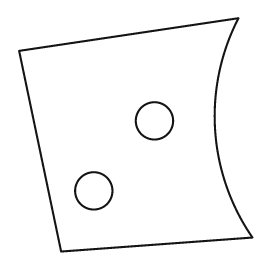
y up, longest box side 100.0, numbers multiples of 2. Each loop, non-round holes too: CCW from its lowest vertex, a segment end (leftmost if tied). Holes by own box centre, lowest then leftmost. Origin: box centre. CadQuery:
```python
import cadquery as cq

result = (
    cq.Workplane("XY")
    .moveTo(-32.0, -50.0)
    .lineTo(50.0, -44.0)
    .threePointArc((34.0, 2.0), (44.0, 50.0))
    .lineTo(-50.0, 36.0)
    .close()
    .moveTo(-18.0, -24.0)
    .circle(8.0)
    .moveTo(8.0, 6.0)
    .circle(8.0)
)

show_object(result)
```